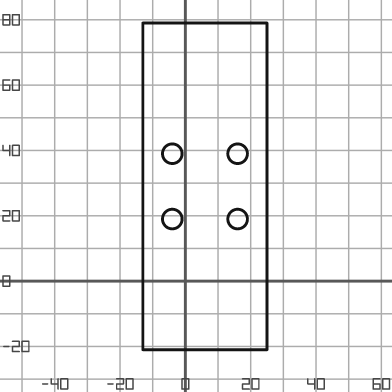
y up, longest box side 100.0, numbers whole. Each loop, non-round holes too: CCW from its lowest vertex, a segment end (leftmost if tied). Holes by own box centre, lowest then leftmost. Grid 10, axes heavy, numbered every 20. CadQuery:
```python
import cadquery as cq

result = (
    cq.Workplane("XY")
    .moveTo(-13.0, -21.0)
    .lineTo(25.0, -21.0)
    .lineTo(25.0, 79.0)
    .lineTo(-13.0, 79.0)
    .close()
    .moveTo(-4.0, 19.0)
    .circle(3.0)
    .moveTo(16.0, 19.0)
    .circle(3.0)
    .moveTo(-4.0, 39.0)
    .circle(3.0)
    .moveTo(16.0, 39.0)
    .circle(3.0)
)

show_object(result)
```